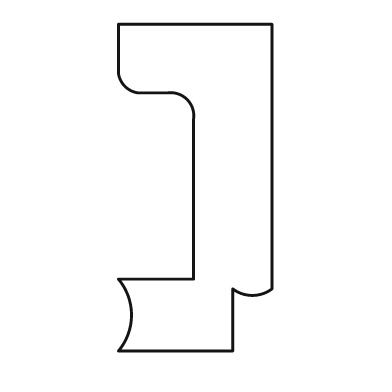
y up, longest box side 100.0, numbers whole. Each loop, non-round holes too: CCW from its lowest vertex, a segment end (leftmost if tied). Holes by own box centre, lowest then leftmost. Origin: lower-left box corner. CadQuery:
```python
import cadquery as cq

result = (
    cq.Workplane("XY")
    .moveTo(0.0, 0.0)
    .lineTo(35.0, 0.0)
    .lineTo(35.0, 19.0)
    .threePointArc((41.0, 17.0), (47.0, 19.0))
    .lineTo(47.0, 100.0)
    .lineTo(0.0, 100.0)
    .lineTo(0.0, 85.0)
    .threePointArc((2.0, 81.0), (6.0, 79.0))
    .lineTo(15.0, 79.0)
    .threePointArc((21.0, 77.0), (23.0, 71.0))
    .lineTo(23.0, 22.0)
    .lineTo(0.0, 22.0)
    .threePointArc((4.0, 11.0), (0.0, 0.0))
    .close()
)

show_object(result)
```